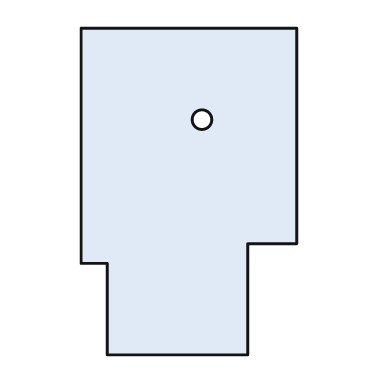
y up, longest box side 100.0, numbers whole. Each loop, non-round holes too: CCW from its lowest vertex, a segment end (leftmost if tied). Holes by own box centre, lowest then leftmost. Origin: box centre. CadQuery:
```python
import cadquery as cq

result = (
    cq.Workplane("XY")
    .moveTo(-25.0, -50.0)
    .lineTo(18.0, -50.0)
    .lineTo(18.0, -16.0)
    .lineTo(33.0, -16.0)
    .lineTo(33.0, 50.0)
    .lineTo(-33.0, 50.0)
    .lineTo(-33.0, -22.0)
    .lineTo(-25.0, -22.0)
    .close()
    .moveTo(4.0, 22.0)
    .circle(3.0)
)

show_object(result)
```